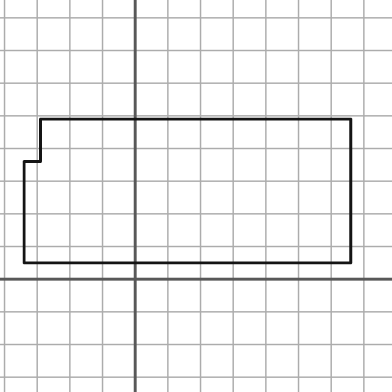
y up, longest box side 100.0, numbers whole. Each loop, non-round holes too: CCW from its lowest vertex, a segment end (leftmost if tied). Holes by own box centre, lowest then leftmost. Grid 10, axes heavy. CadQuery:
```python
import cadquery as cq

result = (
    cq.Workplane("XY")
    .moveTo(-34.0, 5.0)
    .lineTo(66.0, 5.0)
    .lineTo(66.0, 49.0)
    .lineTo(-29.0, 49.0)
    .lineTo(-29.0, 36.0)
    .lineTo(-34.0, 36.0)
    .close()
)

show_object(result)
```